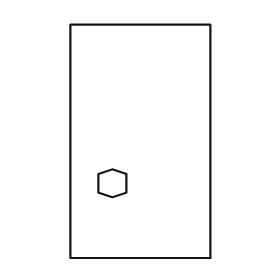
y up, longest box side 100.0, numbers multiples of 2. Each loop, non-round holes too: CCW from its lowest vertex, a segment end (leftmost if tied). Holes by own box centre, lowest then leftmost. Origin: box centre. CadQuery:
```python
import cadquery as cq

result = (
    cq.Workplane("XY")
    .moveTo(-30.0, -50.0)
    .lineTo(30.0, -50.0)
    .lineTo(30.0, 50.0)
    .lineTo(-30.0, 50.0)
    .close()
    .moveTo(-12.0, -24.0)
    .lineTo(-6.0, -22.0)
    .lineTo(-6.0, -14.0)
    .lineTo(-12.0, -12.0)
    .lineTo(-18.0, -14.0)
    .lineTo(-18.0, -22.0)
    .close()
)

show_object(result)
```